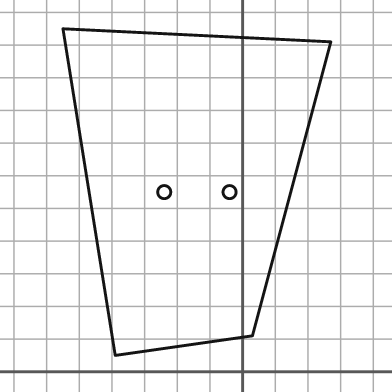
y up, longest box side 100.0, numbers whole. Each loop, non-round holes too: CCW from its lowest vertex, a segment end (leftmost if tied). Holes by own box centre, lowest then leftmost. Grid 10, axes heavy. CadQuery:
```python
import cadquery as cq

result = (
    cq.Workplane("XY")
    .moveTo(-39.0, 5.0)
    .lineTo(3.0, 11.0)
    .lineTo(27.0, 101.0)
    .lineTo(-55.0, 105.0)
    .close()
    .moveTo(-24.0, 55.0)
    .circle(2.0)
    .moveTo(-4.0, 55.0)
    .circle(2.0)
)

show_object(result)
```